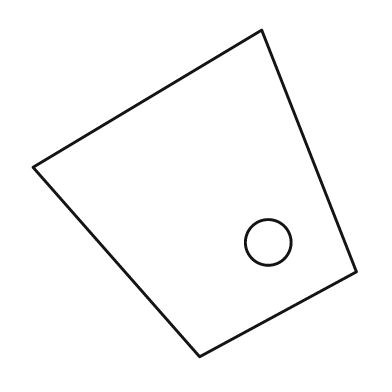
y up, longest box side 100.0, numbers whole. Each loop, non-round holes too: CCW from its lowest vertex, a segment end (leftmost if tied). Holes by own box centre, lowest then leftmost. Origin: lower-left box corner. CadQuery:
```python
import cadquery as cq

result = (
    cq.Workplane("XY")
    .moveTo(51.0, 0.0)
    .lineTo(99.0, 26.0)
    .lineTo(70.0, 100.0)
    .lineTo(0.0, 58.0)
    .close()
    .moveTo(72.0, 35.0)
    .circle(7.0)
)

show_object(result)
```